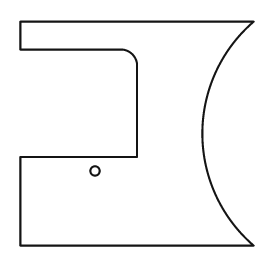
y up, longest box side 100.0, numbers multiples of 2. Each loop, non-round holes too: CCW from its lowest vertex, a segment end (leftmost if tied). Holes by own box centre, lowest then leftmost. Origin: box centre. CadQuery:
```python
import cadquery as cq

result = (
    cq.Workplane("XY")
    .moveTo(-50.0, -48.0)
    .lineTo(50.0, -48.0)
    .threePointArc((28.0, 0.0), (50.0, 48.0))
    .lineTo(-50.0, 48.0)
    .lineTo(-50.0, 36.0)
    .lineTo(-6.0, 36.0)
    .threePointArc((-2.0, 34.0), (0.0, 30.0))
    .lineTo(0.0, -10.0)
    .lineTo(-50.0, -10.0)
    .close()
    .moveTo(-18.0, -16.0)
    .circle(2.0)
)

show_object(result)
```